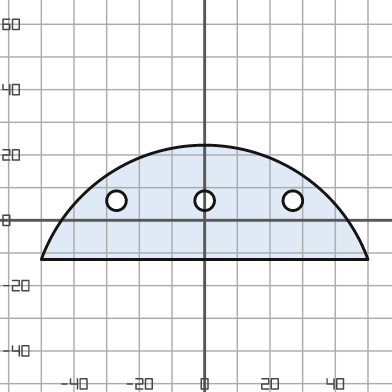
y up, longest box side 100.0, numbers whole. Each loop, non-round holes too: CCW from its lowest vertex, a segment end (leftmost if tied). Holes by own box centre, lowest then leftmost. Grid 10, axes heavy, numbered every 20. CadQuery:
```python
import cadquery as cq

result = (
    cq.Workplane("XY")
    .moveTo(-50.0, -12.0)
    .lineTo(50.0, -12.0)
    .threePointArc((0.0, 23.0), (-50.0, -12.0))
    .close()
    .moveTo(-27.0, 6.0)
    .circle(3.0)
    .moveTo(0.0, 6.0)
    .circle(3.0)
    .moveTo(27.0, 6.0)
    .circle(3.0)
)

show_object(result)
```